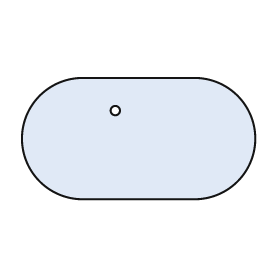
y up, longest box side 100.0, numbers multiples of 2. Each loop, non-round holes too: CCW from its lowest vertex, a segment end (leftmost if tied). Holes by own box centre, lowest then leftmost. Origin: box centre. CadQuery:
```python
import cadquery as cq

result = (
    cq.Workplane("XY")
    .moveTo(-24.0, -26.0)
    .lineTo(24.0, -26.0)
    .threePointArc((50.0, 0.0), (24.0, 26.0))
    .lineTo(-24.0, 26.0)
    .threePointArc((-50.0, 0.0), (-24.0, -26.0))
    .close()
    .moveTo(-10.0, 12.0)
    .circle(2.0)
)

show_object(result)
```